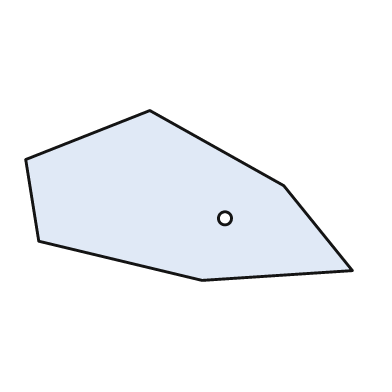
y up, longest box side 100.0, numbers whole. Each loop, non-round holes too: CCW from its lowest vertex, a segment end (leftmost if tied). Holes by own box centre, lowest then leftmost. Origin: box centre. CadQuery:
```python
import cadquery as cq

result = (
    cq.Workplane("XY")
    .moveTo(4.0, -26.0)
    .lineTo(50.0, -23.0)
    .lineTo(29.0, 3.0)
    .lineTo(-12.0, 26.0)
    .lineTo(-50.0, 11.0)
    .lineTo(-46.0, -14.0)
    .close()
    .moveTo(11.0, -7.0)
    .circle(2.0)
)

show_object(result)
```